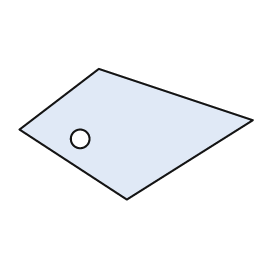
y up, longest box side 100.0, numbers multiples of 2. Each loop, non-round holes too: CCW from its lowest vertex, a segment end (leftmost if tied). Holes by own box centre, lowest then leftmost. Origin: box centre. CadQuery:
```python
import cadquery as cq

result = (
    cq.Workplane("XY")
    .moveTo(-4.0, -28.0)
    .lineTo(50.0, 6.0)
    .lineTo(-16.0, 28.0)
    .lineTo(-50.0, 2.0)
    .close()
    .moveTo(-24.0, -2.0)
    .circle(4.0)
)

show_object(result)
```